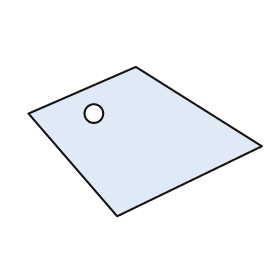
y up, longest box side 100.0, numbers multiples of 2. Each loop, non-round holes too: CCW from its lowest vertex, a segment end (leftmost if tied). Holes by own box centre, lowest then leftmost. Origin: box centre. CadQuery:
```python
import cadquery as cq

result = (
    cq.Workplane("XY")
    .moveTo(-12.0, -32.0)
    .lineTo(50.0, -2.0)
    .lineTo(-4.0, 32.0)
    .lineTo(-50.0, 12.0)
    .close()
    .moveTo(-22.0, 12.0)
    .circle(4.0)
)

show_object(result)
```